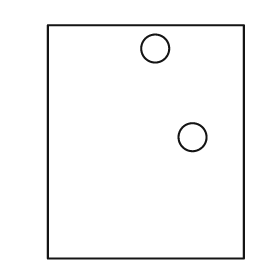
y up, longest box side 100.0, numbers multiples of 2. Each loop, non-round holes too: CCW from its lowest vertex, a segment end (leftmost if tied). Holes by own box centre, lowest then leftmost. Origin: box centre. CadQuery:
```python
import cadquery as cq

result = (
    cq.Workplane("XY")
    .moveTo(-42.0, -50.0)
    .lineTo(42.0, -50.0)
    .lineTo(42.0, 50.0)
    .lineTo(-42.0, 50.0)
    .close()
    .moveTo(20.0, 2.0)
    .circle(6.0)
    .moveTo(4.0, 40.0)
    .circle(6.0)
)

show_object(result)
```